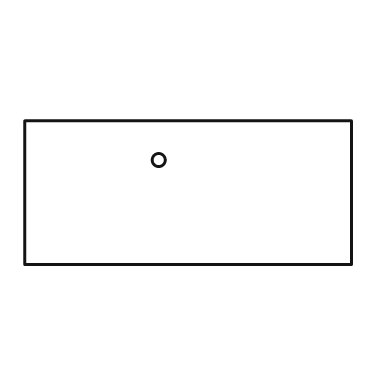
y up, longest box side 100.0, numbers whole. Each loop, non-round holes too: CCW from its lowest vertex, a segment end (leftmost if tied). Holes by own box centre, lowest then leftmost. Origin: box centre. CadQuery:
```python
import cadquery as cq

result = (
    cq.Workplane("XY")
    .moveTo(-50.0, -22.0)
    .lineTo(50.0, -22.0)
    .lineTo(50.0, 22.0)
    .lineTo(-50.0, 22.0)
    .close()
    .moveTo(-9.0, 10.0)
    .circle(2.0)
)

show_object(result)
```